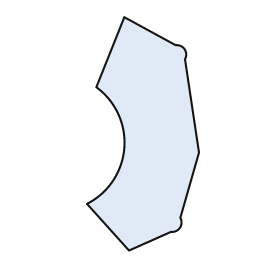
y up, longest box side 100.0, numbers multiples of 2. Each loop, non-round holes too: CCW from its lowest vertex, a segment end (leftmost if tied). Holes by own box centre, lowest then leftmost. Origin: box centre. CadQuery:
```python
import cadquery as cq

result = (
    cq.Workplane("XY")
    .moveTo(-6.0, -50.0)
    .lineTo(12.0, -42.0)
    .threePointArc((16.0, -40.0), (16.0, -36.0))
    .lineTo(24.0, -8.0)
    .lineTo(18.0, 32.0)
    .threePointArc((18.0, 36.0), (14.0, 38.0))
    .lineTo(-8.0, 50.0)
    .lineTo(-20.0, 20.0)
    .threePointArc((-8.0, -6.0), (-24.0, -30.0))
    .close()
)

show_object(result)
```